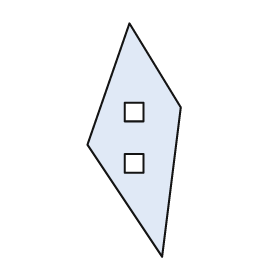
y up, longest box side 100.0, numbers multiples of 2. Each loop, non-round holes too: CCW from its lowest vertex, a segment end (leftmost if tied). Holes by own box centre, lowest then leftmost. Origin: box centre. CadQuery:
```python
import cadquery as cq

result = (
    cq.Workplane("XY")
    .moveTo(12.0, -50.0)
    .lineTo(20.0, 14.0)
    .lineTo(-2.0, 50.0)
    .lineTo(-20.0, -2.0)
    .close()
    .moveTo(-4.0, -14.0)
    .lineTo(4.0, -14.0)
    .lineTo(4.0, -6.0)
    .lineTo(-4.0, -6.0)
    .close()
    .moveTo(-4.0, 8.0)
    .lineTo(4.0, 8.0)
    .lineTo(4.0, 16.0)
    .lineTo(-4.0, 16.0)
    .close()
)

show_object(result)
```